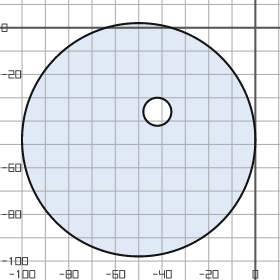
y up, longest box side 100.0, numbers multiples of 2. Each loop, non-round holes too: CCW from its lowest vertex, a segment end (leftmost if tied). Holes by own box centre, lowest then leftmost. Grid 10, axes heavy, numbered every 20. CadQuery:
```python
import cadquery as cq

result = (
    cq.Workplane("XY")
    .moveTo(-50.0, -48.0)
    .circle(50.0)
    .moveTo(-42.0, -36.0)
    .circle(6.0)
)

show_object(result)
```